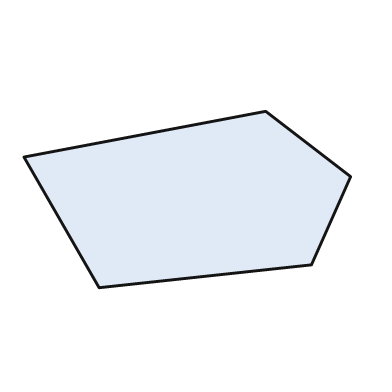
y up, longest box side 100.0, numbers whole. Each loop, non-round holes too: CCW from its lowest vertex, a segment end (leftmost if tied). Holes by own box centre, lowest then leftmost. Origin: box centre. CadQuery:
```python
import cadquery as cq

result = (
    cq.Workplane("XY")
    .moveTo(-27.0, -27.0)
    .lineTo(38.0, -20.0)
    .lineTo(50.0, 7.0)
    .lineTo(24.0, 27.0)
    .lineTo(-50.0, 13.0)
    .close()
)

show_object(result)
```